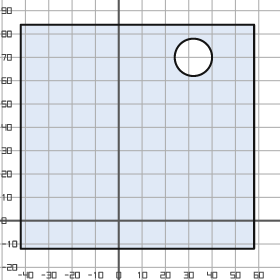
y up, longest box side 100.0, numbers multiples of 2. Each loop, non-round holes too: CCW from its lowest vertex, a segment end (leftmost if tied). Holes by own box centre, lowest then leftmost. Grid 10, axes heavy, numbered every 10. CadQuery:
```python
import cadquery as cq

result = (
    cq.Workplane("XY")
    .moveTo(-42.0, -12.0)
    .lineTo(58.0, -12.0)
    .lineTo(58.0, 84.0)
    .lineTo(-42.0, 84.0)
    .close()
    .moveTo(32.0, 70.0)
    .circle(8.0)
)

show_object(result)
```